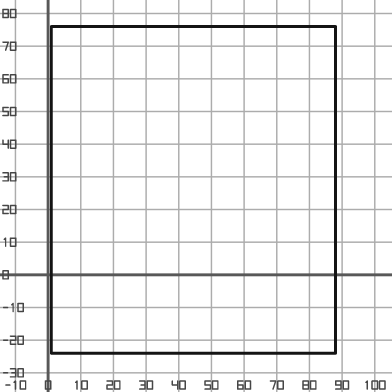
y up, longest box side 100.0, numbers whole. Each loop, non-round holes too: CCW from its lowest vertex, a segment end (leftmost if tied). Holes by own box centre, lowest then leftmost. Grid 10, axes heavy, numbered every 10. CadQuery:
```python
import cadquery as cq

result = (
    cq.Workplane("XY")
    .moveTo(1.0, -24.0)
    .lineTo(88.0, -24.0)
    .lineTo(88.0, 76.0)
    .lineTo(1.0, 76.0)
    .close()
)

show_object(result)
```